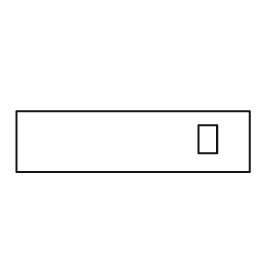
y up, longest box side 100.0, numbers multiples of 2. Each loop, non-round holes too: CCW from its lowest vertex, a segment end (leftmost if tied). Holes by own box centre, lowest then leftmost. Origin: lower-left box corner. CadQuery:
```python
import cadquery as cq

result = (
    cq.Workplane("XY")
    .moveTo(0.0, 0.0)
    .lineTo(100.0, 0.0)
    .lineTo(100.0, 26.0)
    .lineTo(0.0, 26.0)
    .close()
    .moveTo(78.0, 8.0)
    .lineTo(86.0, 8.0)
    .lineTo(86.0, 20.0)
    .lineTo(78.0, 20.0)
    .close()
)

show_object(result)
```